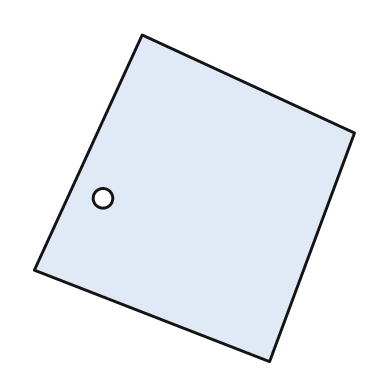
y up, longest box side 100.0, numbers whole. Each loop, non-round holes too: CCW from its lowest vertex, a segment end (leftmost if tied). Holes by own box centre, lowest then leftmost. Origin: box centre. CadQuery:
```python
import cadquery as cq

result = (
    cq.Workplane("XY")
    .moveTo(23.0, -50.0)
    .lineTo(49.0, 20.0)
    .lineTo(-16.0, 50.0)
    .lineTo(-49.0, -22.0)
    .close()
    .moveTo(-28.0, 0.0)
    .circle(3.0)
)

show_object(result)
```